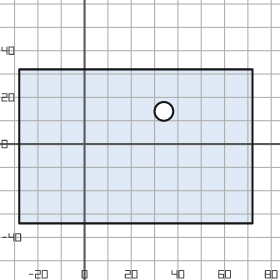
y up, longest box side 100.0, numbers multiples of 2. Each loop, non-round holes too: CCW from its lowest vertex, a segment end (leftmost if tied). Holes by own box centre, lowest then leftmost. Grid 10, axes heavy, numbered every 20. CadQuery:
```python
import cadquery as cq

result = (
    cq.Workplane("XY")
    .moveTo(-28.0, -34.0)
    .lineTo(72.0, -34.0)
    .lineTo(72.0, 32.0)
    .lineTo(-28.0, 32.0)
    .close()
    .moveTo(34.0, 14.0)
    .circle(4.0)
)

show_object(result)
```